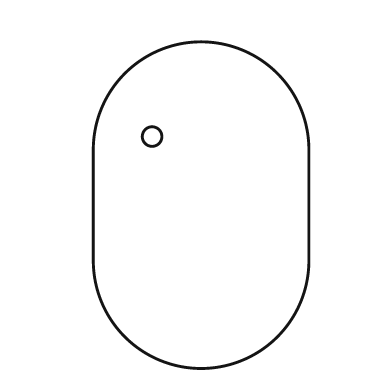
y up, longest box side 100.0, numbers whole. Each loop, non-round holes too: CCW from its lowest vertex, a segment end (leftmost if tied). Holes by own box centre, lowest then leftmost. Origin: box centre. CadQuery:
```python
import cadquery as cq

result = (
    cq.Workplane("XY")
    .moveTo(-33.0, -17.0)
    .threePointArc((0.0, -50.0), (33.0, -17.0))
    .lineTo(33.0, 17.0)
    .threePointArc((0.0, 50.0), (-33.0, 17.0))
    .close()
    .moveTo(-15.0, 21.0)
    .circle(3.0)
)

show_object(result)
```